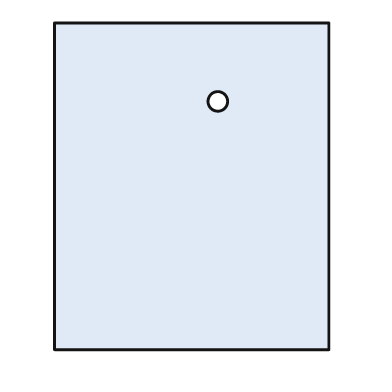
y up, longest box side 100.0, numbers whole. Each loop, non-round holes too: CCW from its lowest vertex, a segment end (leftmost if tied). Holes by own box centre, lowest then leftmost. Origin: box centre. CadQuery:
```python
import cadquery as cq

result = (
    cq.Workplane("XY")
    .moveTo(-42.0, -50.0)
    .lineTo(42.0, -50.0)
    .lineTo(42.0, 50.0)
    .lineTo(-42.0, 50.0)
    .close()
    .moveTo(8.0, 26.0)
    .circle(3.0)
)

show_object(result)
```